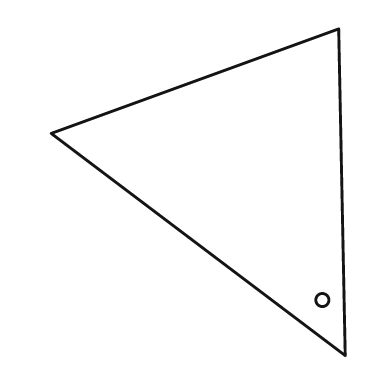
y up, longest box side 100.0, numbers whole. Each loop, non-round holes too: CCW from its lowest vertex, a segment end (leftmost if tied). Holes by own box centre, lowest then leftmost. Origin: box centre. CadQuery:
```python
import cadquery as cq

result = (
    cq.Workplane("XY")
    .moveTo(45.0, -50.0)
    .lineTo(43.0, 50.0)
    .lineTo(-45.0, 18.0)
    .close()
    .moveTo(38.0, -33.0)
    .circle(2.0)
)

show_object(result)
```